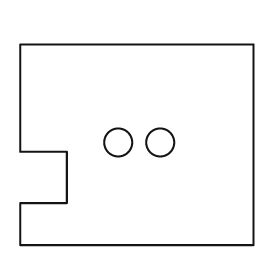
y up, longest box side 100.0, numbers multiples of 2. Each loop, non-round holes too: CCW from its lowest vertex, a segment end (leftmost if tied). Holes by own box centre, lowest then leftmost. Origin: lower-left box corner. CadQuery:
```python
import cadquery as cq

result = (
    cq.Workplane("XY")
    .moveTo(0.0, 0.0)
    .lineTo(100.0, 0.0)
    .lineTo(100.0, 86.0)
    .lineTo(0.0, 86.0)
    .lineTo(0.0, 40.0)
    .lineTo(20.0, 40.0)
    .lineTo(20.0, 18.0)
    .lineTo(0.0, 18.0)
    .close()
    .moveTo(42.0, 44.0)
    .circle(6.0)
    .moveTo(60.0, 44.0)
    .circle(6.0)
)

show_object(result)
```